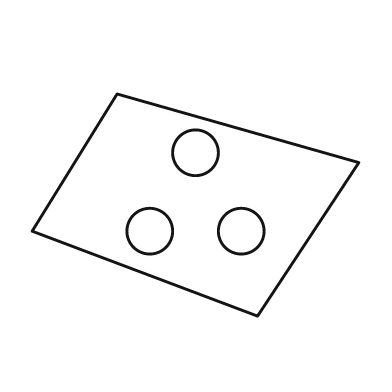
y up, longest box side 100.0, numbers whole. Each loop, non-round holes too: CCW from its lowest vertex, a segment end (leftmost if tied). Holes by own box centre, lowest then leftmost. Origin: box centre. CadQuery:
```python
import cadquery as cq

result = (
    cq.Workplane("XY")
    .moveTo(19.0, -34.0)
    .lineTo(50.0, 13.0)
    .lineTo(-24.0, 34.0)
    .lineTo(-50.0, -8.0)
    .close()
    .moveTo(-14.0, -8.0)
    .circle(7.0)
    .moveTo(14.0, -8.0)
    .circle(7.0)
    .moveTo(0.0, 16.0)
    .circle(7.0)
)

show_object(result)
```